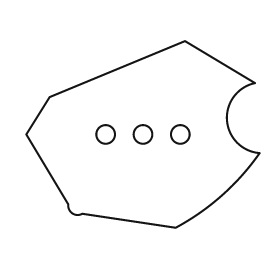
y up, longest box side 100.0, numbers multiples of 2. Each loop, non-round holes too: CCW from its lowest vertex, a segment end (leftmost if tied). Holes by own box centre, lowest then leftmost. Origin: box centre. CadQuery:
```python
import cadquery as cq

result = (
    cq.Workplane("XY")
    .moveTo(14.0, -40.0)
    .threePointArc((34.0, -26.0), (50.0, -8.0))
    .threePointArc((36.0, 6.0), (48.0, 22.0))
    .lineTo(18.0, 40.0)
    .lineTo(-40.0, 16.0)
    .lineTo(-50.0, 0.0)
    .lineTo(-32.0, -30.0)
    .threePointArc((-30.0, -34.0), (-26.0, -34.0))
    .close()
    .moveTo(-16.0, 0.0)
    .circle(4.0)
    .moveTo(0.0, 0.0)
    .circle(4.0)
    .moveTo(16.0, 0.0)
    .circle(4.0)
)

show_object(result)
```